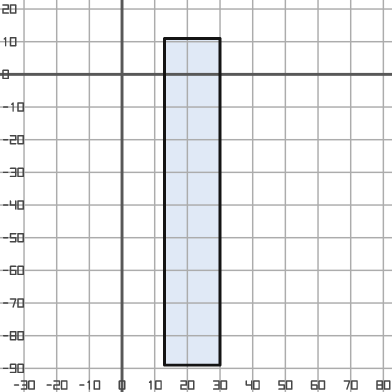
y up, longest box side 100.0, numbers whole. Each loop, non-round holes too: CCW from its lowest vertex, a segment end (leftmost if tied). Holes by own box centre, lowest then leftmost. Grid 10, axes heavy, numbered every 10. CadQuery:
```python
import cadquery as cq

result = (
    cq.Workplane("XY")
    .moveTo(13.0, -89.0)
    .lineTo(30.0, -89.0)
    .lineTo(30.0, 11.0)
    .lineTo(13.0, 11.0)
    .close()
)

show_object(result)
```